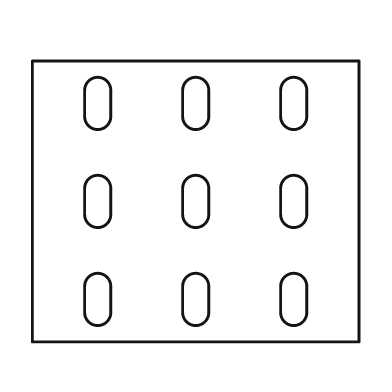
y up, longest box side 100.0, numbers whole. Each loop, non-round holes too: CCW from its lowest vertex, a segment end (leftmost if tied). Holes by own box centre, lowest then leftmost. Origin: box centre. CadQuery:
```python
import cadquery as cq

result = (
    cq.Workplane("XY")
    .moveTo(-50.0, -43.0)
    .lineTo(50.0, -43.0)
    .lineTo(50.0, 43.0)
    .lineTo(-50.0, 43.0)
    .close()
    .moveTo(-34.0, -34.0)
    .threePointArc((-30.0, -38.0), (-26.0, -34.0))
    .lineTo(-26.0, -26.0)
    .threePointArc((-30.0, -22.0), (-34.0, -26.0))
    .close()
    .moveTo(-4.0, -34.0)
    .threePointArc((0.0, -38.0), (4.0, -34.0))
    .lineTo(4.0, -26.0)
    .threePointArc((0.0, -22.0), (-4.0, -26.0))
    .close()
    .moveTo(26.0, -34.0)
    .threePointArc((30.0, -38.0), (34.0, -34.0))
    .lineTo(34.0, -26.0)
    .threePointArc((30.0, -22.0), (26.0, -26.0))
    .close()
    .moveTo(-34.0, -4.0)
    .threePointArc((-30.0, -8.0), (-26.0, -4.0))
    .lineTo(-26.0, 4.0)
    .threePointArc((-30.0, 8.0), (-34.0, 4.0))
    .close()
    .moveTo(-4.0, -4.0)
    .threePointArc((0.0, -8.0), (4.0, -4.0))
    .lineTo(4.0, 4.0)
    .threePointArc((0.0, 8.0), (-4.0, 4.0))
    .close()
    .moveTo(26.0, -4.0)
    .threePointArc((30.0, -8.0), (34.0, -4.0))
    .lineTo(34.0, 4.0)
    .threePointArc((30.0, 8.0), (26.0, 4.0))
    .close()
    .moveTo(-34.0, 26.0)
    .threePointArc((-30.0, 22.0), (-26.0, 26.0))
    .lineTo(-26.0, 34.0)
    .threePointArc((-30.0, 38.0), (-34.0, 34.0))
    .close()
    .moveTo(-4.0, 26.0)
    .threePointArc((0.0, 22.0), (4.0, 26.0))
    .lineTo(4.0, 34.0)
    .threePointArc((0.0, 38.0), (-4.0, 34.0))
    .close()
    .moveTo(26.0, 26.0)
    .threePointArc((30.0, 22.0), (34.0, 26.0))
    .lineTo(34.0, 34.0)
    .threePointArc((30.0, 38.0), (26.0, 34.0))
    .close()
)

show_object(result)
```